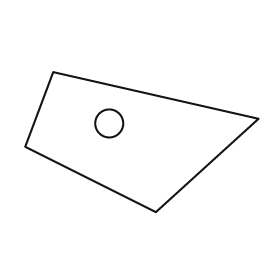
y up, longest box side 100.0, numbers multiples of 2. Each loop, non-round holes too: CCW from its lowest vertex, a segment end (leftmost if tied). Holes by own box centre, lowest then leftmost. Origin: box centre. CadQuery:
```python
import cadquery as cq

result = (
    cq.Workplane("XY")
    .moveTo(6.0, -30.0)
    .lineTo(50.0, 10.0)
    .lineTo(-38.0, 30.0)
    .lineTo(-50.0, -2.0)
    .close()
    .moveTo(-14.0, 8.0)
    .circle(6.0)
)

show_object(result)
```